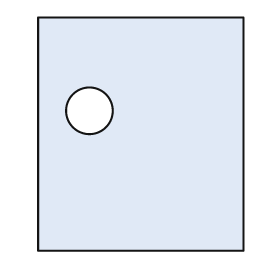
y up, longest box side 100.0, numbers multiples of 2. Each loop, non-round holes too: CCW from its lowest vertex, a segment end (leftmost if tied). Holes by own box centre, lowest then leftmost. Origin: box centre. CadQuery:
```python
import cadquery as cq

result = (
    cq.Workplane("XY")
    .moveTo(-44.0, -50.0)
    .lineTo(44.0, -50.0)
    .lineTo(44.0, 50.0)
    .lineTo(-44.0, 50.0)
    .close()
    .moveTo(-22.0, 10.0)
    .circle(10.0)
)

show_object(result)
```